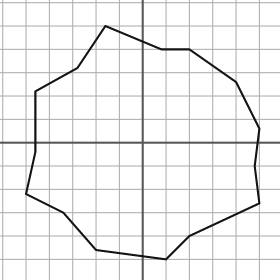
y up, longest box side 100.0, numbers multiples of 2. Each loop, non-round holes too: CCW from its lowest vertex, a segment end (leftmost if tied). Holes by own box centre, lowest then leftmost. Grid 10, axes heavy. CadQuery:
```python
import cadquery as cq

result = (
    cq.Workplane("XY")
    .moveTo(10.0, -50.0)
    .lineTo(20.0, -40.0)
    .lineTo(50.0, -26.0)
    .lineTo(48.0, -10.0)
    .lineTo(50.0, 6.0)
    .lineTo(40.0, 26.0)
    .lineTo(20.0, 40.0)
    .lineTo(8.0, 40.0)
    .lineTo(-16.0, 50.0)
    .lineTo(-28.0, 32.0)
    .lineTo(-46.0, 22.0)
    .lineTo(-46.0, -4.0)
    .lineTo(-50.0, -22.0)
    .lineTo(-34.0, -30.0)
    .lineTo(-20.0, -46.0)
    .close()
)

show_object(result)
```